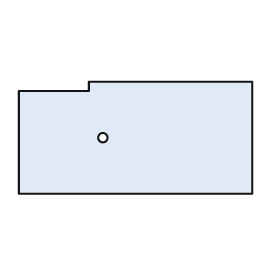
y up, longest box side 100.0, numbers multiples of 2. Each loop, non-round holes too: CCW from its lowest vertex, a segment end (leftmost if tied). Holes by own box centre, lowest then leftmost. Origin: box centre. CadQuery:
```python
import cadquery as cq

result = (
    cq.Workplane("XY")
    .moveTo(-50.0, -24.0)
    .lineTo(50.0, -24.0)
    .lineTo(50.0, 24.0)
    .lineTo(-20.0, 24.0)
    .lineTo(-20.0, 20.0)
    .lineTo(-50.0, 20.0)
    .close()
    .moveTo(-14.0, 0.0)
    .circle(2.0)
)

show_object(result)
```